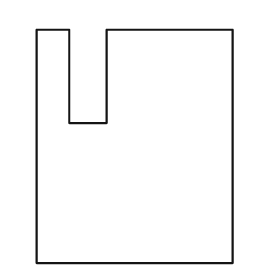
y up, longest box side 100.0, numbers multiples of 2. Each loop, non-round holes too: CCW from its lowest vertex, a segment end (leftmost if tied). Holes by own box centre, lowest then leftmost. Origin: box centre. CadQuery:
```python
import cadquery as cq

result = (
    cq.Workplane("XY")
    .moveTo(-42.0, -50.0)
    .lineTo(42.0, -50.0)
    .lineTo(42.0, 50.0)
    .lineTo(-12.0, 50.0)
    .lineTo(-12.0, 10.0)
    .lineTo(-28.0, 10.0)
    .lineTo(-28.0, 50.0)
    .lineTo(-42.0, 50.0)
    .close()
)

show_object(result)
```